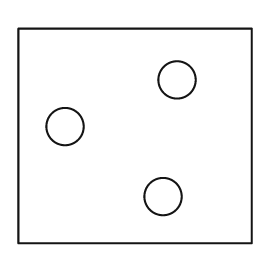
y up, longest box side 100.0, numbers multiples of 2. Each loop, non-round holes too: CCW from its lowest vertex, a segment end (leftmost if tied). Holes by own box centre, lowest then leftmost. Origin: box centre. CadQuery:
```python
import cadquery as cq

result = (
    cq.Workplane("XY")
    .moveTo(-50.0, -46.0)
    .lineTo(50.0, -46.0)
    .lineTo(50.0, 46.0)
    .lineTo(-50.0, 46.0)
    .close()
    .moveTo(12.0, -26.0)
    .circle(8.0)
    .moveTo(-30.0, 4.0)
    .circle(8.0)
    .moveTo(18.0, 24.0)
    .circle(8.0)
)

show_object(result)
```